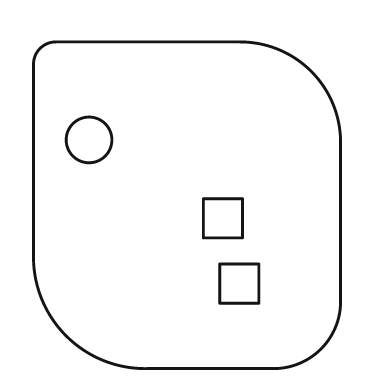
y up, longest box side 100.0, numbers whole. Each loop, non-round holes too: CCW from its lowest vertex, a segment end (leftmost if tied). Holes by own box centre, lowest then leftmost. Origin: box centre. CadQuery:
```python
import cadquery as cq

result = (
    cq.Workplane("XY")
    .moveTo(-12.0, -50.0)
    .lineTo(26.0, -50.0)
    .threePointArc((41.0, -44.0), (47.0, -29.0))
    .lineTo(47.0, 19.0)
    .threePointArc((38.0, 41.0), (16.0, 50.0))
    .lineTo(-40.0, 50.0)
    .threePointArc((-45.0, 48.0), (-47.0, 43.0))
    .lineTo(-47.0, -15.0)
    .threePointArc((-37.0, -40.0), (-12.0, -50.0))
    .close()
    .moveTo(10.0, -30.0)
    .lineTo(22.0, -30.0)
    .lineTo(22.0, -18.0)
    .lineTo(10.0, -18.0)
    .close()
    .moveTo(5.0, -10.0)
    .lineTo(17.0, -10.0)
    .lineTo(17.0, 2.0)
    .lineTo(5.0, 2.0)
    .close()
    .moveTo(-30.0, 20.0)
    .circle(7.0)
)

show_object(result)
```